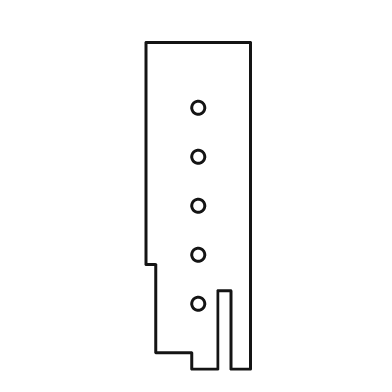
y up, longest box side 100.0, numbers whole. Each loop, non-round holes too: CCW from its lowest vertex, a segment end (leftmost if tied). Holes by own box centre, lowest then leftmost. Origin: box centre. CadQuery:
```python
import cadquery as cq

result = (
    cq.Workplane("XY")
    .moveTo(-2.0, -50.0)
    .lineTo(6.0, -50.0)
    .lineTo(6.0, -26.0)
    .lineTo(10.0, -26.0)
    .lineTo(10.0, -50.0)
    .lineTo(16.0, -50.0)
    .lineTo(16.0, 50.0)
    .lineTo(-16.0, 50.0)
    .lineTo(-16.0, -18.0)
    .lineTo(-13.0, -18.0)
    .lineTo(-13.0, -45.0)
    .lineTo(-2.0, -45.0)
    .close()
    .moveTo(0.0, -30.0)
    .circle(2.0)
    .moveTo(0.0, -15.0)
    .circle(2.0)
    .moveTo(0.0, 0.0)
    .circle(2.0)
    .moveTo(0.0, 15.0)
    .circle(2.0)
    .moveTo(0.0, 30.0)
    .circle(2.0)
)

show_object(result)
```